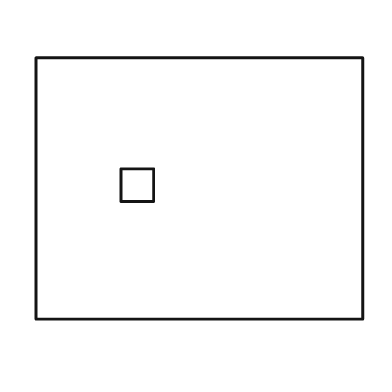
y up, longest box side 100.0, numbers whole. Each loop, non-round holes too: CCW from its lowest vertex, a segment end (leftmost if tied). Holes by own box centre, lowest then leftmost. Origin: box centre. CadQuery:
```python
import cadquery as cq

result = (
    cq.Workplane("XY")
    .moveTo(-50.0, -40.0)
    .lineTo(50.0, -40.0)
    .lineTo(50.0, 40.0)
    .lineTo(-50.0, 40.0)
    .close()
    .moveTo(-24.0, -4.0)
    .lineTo(-14.0, -4.0)
    .lineTo(-14.0, 6.0)
    .lineTo(-24.0, 6.0)
    .close()
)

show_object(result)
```